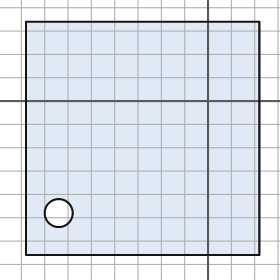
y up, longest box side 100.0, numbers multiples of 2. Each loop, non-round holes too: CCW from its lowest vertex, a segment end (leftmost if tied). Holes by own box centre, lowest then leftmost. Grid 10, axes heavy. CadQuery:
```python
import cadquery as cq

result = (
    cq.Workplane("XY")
    .moveTo(-78.0, -66.0)
    .lineTo(22.0, -66.0)
    .lineTo(22.0, 34.0)
    .lineTo(-78.0, 34.0)
    .close()
    .moveTo(-64.0, -48.0)
    .circle(6.0)
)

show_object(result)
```